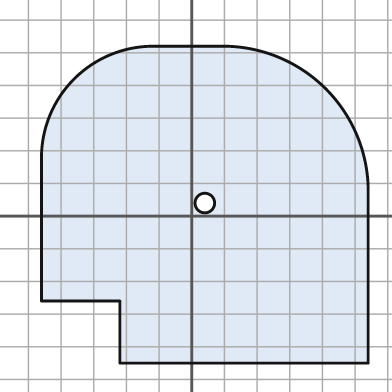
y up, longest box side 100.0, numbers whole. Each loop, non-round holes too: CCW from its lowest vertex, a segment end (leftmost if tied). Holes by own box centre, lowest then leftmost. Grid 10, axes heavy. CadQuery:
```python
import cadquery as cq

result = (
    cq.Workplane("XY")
    .moveTo(-22.0, -45.0)
    .lineTo(54.0, -45.0)
    .lineTo(54.0, 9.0)
    .threePointArc((41.0, 39.0), (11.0, 52.0))
    .lineTo(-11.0, 52.0)
    .threePointArc((-36.0, 42.0), (-46.0, 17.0))
    .lineTo(-46.0, -26.0)
    .lineTo(-22.0, -26.0)
    .close()
    .moveTo(4.0, 4.0)
    .circle(3.0)
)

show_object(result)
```